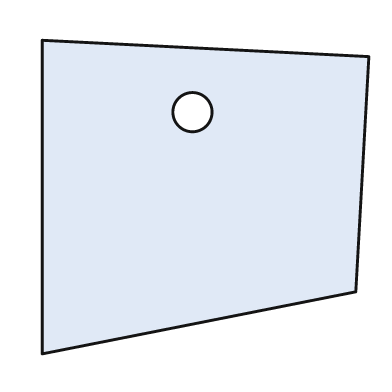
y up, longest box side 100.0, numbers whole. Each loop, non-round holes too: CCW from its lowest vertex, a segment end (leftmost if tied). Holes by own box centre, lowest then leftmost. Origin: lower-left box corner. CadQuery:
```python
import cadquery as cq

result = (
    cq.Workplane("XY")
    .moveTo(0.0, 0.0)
    .lineTo(96.0, 19.0)
    .lineTo(100.0, 91.0)
    .lineTo(0.0, 96.0)
    .close()
    .moveTo(46.0, 74.0)
    .circle(6.0)
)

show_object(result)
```